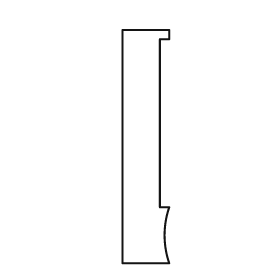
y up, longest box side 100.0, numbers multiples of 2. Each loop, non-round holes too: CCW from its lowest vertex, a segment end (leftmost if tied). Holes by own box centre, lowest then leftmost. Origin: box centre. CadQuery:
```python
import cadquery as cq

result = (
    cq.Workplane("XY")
    .moveTo(-10.0, -50.0)
    .lineTo(10.0, -50.0)
    .threePointArc((8.0, -38.0), (10.0, -26.0))
    .lineTo(6.0, -26.0)
    .lineTo(6.0, 46.0)
    .lineTo(10.0, 46.0)
    .lineTo(10.0, 50.0)
    .lineTo(-10.0, 50.0)
    .close()
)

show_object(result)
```